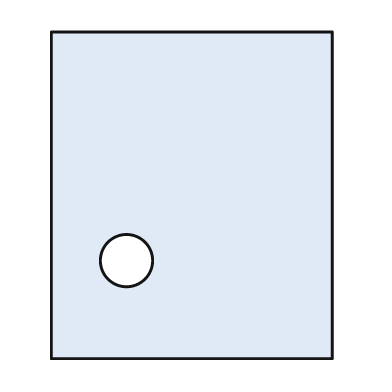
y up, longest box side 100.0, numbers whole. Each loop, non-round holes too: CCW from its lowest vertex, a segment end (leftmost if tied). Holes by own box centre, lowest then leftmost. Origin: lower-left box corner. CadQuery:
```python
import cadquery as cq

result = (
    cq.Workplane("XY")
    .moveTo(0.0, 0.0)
    .lineTo(86.0, 0.0)
    .lineTo(86.0, 100.0)
    .lineTo(0.0, 100.0)
    .close()
    .moveTo(23.0, 30.0)
    .circle(8.0)
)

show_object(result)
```